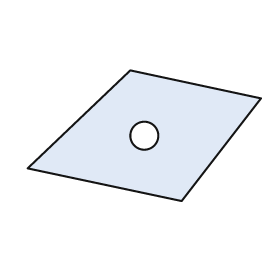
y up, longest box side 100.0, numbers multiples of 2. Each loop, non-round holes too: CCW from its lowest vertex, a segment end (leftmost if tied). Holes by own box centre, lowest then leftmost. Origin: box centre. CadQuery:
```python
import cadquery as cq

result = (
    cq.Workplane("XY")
    .moveTo(16.0, -28.0)
    .lineTo(50.0, 16.0)
    .lineTo(-6.0, 28.0)
    .lineTo(-50.0, -14.0)
    .close()
    .moveTo(0.0, 0.0)
    .circle(6.0)
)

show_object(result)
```